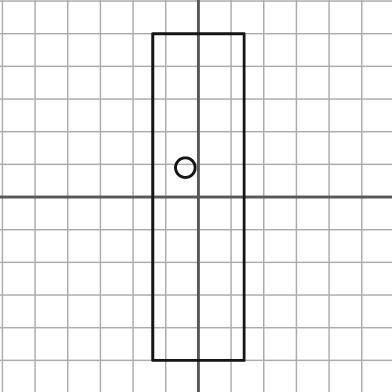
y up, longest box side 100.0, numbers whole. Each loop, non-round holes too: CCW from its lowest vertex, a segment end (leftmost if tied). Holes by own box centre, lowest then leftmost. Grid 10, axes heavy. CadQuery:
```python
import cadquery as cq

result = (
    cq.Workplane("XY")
    .moveTo(-14.0, -50.0)
    .lineTo(14.0, -50.0)
    .lineTo(14.0, 50.0)
    .lineTo(-14.0, 50.0)
    .close()
    .moveTo(-4.0, 9.0)
    .circle(3.0)
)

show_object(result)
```